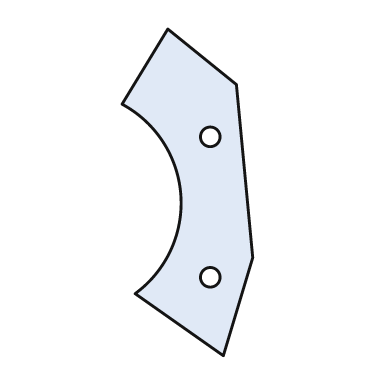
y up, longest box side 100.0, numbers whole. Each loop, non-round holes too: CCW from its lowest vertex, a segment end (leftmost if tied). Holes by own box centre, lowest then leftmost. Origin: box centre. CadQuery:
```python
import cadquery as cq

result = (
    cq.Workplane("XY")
    .moveTo(11.0, -50.0)
    .lineTo(20.0, -20.0)
    .lineTo(15.0, 33.0)
    .lineTo(-6.0, 50.0)
    .lineTo(-20.0, 27.0)
    .threePointArc((-2.0, -1.0), (-16.0, -31.0))
    .close()
    .moveTo(7.0, -26.0)
    .circle(3.0)
    .moveTo(7.0, 17.0)
    .circle(3.0)
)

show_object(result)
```